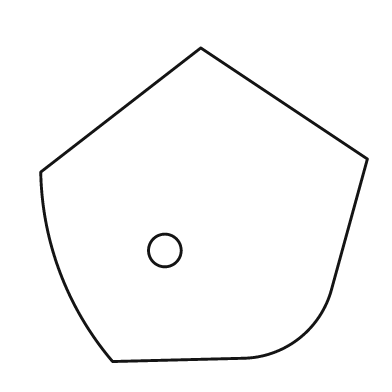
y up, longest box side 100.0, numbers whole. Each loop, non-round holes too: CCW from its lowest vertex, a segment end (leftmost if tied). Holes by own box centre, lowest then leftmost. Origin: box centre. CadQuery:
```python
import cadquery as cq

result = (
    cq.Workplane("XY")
    .moveTo(-28.0, -48.0)
    .lineTo(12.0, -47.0)
    .threePointArc((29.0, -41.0), (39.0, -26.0))
    .lineTo(50.0, 14.0)
    .lineTo(-1.0, 48.0)
    .lineTo(-50.0, 10.0)
    .threePointArc((-44.0, -21.0), (-28.0, -48.0))
    .close()
    .moveTo(-12.0, -14.0)
    .circle(5.0)
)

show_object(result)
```